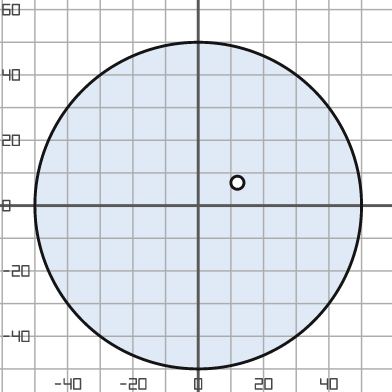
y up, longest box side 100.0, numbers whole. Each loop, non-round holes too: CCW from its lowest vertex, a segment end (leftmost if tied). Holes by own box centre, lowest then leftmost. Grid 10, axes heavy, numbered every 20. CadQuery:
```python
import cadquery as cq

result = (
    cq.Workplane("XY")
    .moveTo(0.0, 0.0)
    .circle(50.0)
    .moveTo(12.0, 7.0)
    .circle(2.0)
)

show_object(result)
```